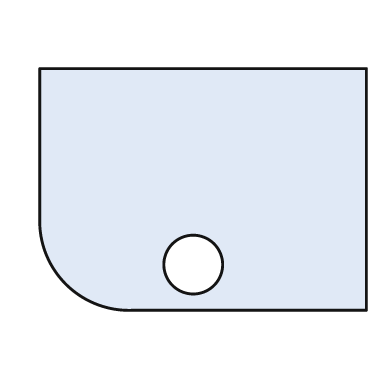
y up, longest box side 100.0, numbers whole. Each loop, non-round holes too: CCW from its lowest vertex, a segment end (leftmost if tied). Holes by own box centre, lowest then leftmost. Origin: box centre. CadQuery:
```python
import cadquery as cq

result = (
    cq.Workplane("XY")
    .moveTo(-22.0, -37.0)
    .lineTo(50.0, -37.0)
    .lineTo(50.0, 37.0)
    .lineTo(-50.0, 37.0)
    .lineTo(-50.0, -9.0)
    .threePointArc((-42.0, -29.0), (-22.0, -37.0))
    .close()
    .moveTo(-3.0, -23.0)
    .circle(9.0)
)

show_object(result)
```